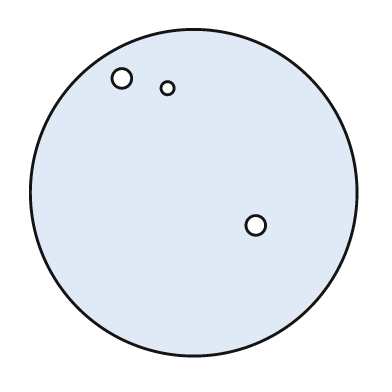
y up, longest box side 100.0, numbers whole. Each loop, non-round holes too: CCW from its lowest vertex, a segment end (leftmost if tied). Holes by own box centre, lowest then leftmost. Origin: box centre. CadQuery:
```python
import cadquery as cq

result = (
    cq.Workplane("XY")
    .moveTo(0.0, 0.0)
    .circle(50.0)
    .moveTo(19.0, -10.0)
    .circle(3.0)
    .moveTo(-8.0, 32.0)
    .circle(2.0)
    .moveTo(-22.0, 35.0)
    .circle(3.0)
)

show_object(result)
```